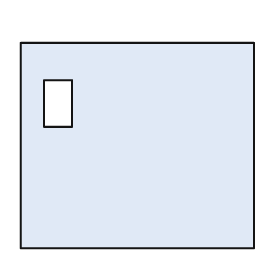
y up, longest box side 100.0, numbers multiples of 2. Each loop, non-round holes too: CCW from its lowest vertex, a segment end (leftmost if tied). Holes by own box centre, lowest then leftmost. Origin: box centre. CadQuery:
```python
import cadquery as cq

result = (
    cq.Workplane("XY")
    .moveTo(-50.0, -44.0)
    .lineTo(50.0, -44.0)
    .lineTo(50.0, 44.0)
    .lineTo(-50.0, 44.0)
    .close()
    .moveTo(-40.0, 8.0)
    .lineTo(-28.0, 8.0)
    .lineTo(-28.0, 28.0)
    .lineTo(-40.0, 28.0)
    .close()
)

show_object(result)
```